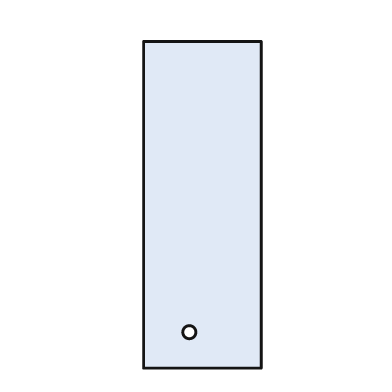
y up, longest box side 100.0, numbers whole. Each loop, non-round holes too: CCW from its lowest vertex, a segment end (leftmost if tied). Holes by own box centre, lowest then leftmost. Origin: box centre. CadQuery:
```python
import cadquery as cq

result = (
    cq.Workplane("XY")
    .moveTo(-18.0, -50.0)
    .lineTo(18.0, -50.0)
    .lineTo(18.0, 50.0)
    .lineTo(-18.0, 50.0)
    .close()
    .moveTo(-4.0, -39.0)
    .circle(2.0)
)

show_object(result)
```